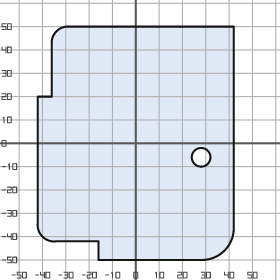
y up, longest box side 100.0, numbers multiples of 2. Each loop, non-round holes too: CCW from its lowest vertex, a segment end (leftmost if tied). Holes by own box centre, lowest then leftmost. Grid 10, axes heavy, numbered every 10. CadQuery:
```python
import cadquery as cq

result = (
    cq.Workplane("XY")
    .moveTo(-16.0, -50.0)
    .lineTo(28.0, -50.0)
    .threePointArc((38.0, -46.0), (42.0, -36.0))
    .lineTo(42.0, 50.0)
    .lineTo(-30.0, 50.0)
    .threePointArc((-34.0, 48.0), (-36.0, 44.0))
    .lineTo(-36.0, 20.0)
    .lineTo(-42.0, 20.0)
    .lineTo(-42.0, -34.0)
    .threePointArc((-40.0, -40.0), (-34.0, -42.0))
    .lineTo(-16.0, -42.0)
    .close()
    .moveTo(28.0, -6.0)
    .circle(4.0)
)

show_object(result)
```